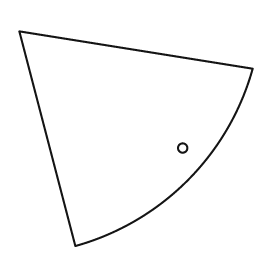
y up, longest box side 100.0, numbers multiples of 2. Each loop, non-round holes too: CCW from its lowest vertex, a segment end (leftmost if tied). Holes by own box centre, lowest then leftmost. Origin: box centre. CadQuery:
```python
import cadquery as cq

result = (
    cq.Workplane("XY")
    .moveTo(-26.0, -46.0)
    .threePointArc((22.0, -18.0), (50.0, 30.0))
    .lineTo(-50.0, 46.0)
    .close()
    .moveTo(20.0, -4.0)
    .circle(2.0)
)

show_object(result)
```